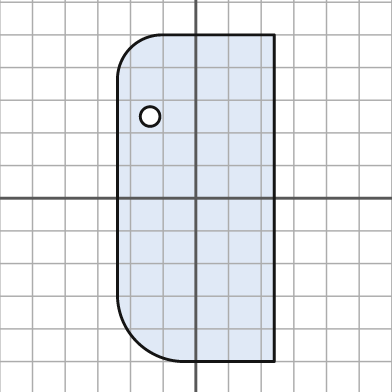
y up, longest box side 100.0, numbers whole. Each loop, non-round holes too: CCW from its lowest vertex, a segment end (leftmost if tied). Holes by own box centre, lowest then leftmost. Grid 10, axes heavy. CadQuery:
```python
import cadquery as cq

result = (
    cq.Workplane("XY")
    .moveTo(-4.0, -50.0)
    .lineTo(24.0, -50.0)
    .lineTo(24.0, 50.0)
    .lineTo(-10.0, 50.0)
    .threePointArc((-20.0, 46.0), (-24.0, 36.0))
    .lineTo(-24.0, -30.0)
    .threePointArc((-18.0, -44.0), (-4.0, -50.0))
    .close()
    .moveTo(-14.0, 25.0)
    .circle(3.0)
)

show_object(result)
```